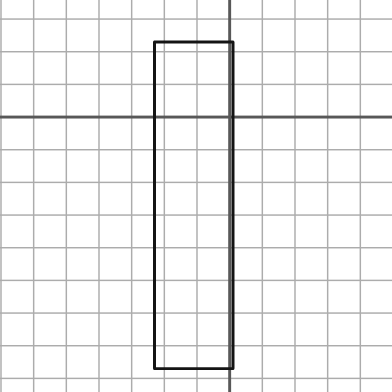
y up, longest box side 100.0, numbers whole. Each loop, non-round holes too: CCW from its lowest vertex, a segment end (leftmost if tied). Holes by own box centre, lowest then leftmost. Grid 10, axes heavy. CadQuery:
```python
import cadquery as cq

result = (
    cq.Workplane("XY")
    .moveTo(-23.0, -77.0)
    .lineTo(1.0, -77.0)
    .lineTo(1.0, 23.0)
    .lineTo(-23.0, 23.0)
    .close()
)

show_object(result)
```